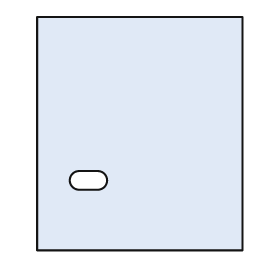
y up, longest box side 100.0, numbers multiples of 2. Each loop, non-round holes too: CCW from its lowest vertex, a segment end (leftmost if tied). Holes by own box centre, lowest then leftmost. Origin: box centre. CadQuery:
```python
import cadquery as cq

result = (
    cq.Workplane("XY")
    .moveTo(-44.0, -50.0)
    .lineTo(44.0, -50.0)
    .lineTo(44.0, 50.0)
    .lineTo(-44.0, 50.0)
    .close()
    .moveTo(-26.0, -24.0)
    .lineTo(-18.0, -24.0)
    .threePointArc((-14.0, -20.0), (-18.0, -16.0))
    .lineTo(-26.0, -16.0)
    .threePointArc((-30.0, -20.0), (-26.0, -24.0))
    .close()
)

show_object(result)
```